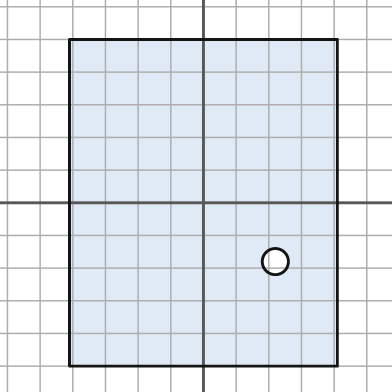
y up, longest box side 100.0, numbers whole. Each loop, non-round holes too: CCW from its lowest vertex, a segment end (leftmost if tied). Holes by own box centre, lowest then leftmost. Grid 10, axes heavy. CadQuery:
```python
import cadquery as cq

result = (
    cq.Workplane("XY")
    .moveTo(-41.0, -50.0)
    .lineTo(41.0, -50.0)
    .lineTo(41.0, 50.0)
    .lineTo(-41.0, 50.0)
    .close()
    .moveTo(22.0, -18.0)
    .circle(4.0)
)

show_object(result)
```